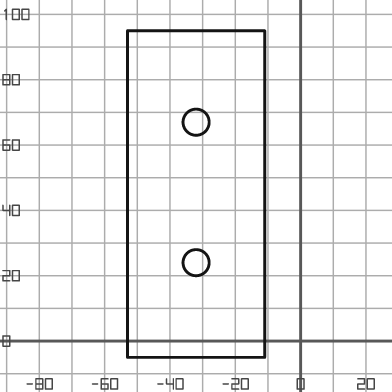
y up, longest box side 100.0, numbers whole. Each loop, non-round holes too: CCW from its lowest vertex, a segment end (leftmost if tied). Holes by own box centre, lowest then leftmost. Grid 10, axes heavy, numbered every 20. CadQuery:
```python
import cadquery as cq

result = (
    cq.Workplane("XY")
    .moveTo(-53.0, -5.0)
    .lineTo(-11.0, -5.0)
    .lineTo(-11.0, 95.0)
    .lineTo(-53.0, 95.0)
    .close()
    .moveTo(-32.0, 24.0)
    .circle(4.0)
    .moveTo(-32.0, 67.0)
    .circle(4.0)
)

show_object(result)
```